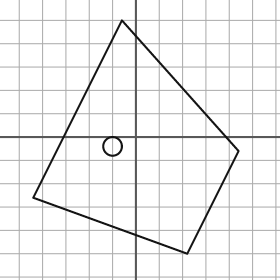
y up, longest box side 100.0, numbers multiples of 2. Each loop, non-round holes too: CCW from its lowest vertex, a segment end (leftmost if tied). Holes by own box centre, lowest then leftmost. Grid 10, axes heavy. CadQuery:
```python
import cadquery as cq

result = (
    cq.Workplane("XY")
    .moveTo(22.0, -50.0)
    .lineTo(44.0, -6.0)
    .lineTo(-6.0, 50.0)
    .lineTo(-44.0, -26.0)
    .close()
    .moveTo(-10.0, -4.0)
    .circle(4.0)
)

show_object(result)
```